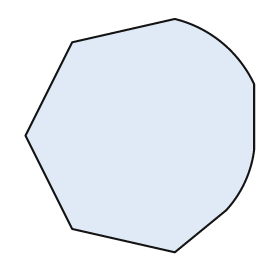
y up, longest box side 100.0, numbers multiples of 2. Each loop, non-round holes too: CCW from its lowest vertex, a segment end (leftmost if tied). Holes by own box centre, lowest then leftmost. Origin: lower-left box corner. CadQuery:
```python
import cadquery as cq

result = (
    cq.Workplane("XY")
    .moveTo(64.0, 0.0)
    .lineTo(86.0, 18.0)
    .threePointArc((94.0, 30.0), (98.0, 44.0))
    .lineTo(98.0, 72.0)
    .threePointArc((84.0, 90.0), (64.0, 100.0))
    .lineTo(20.0, 90.0)
    .lineTo(0.0, 50.0)
    .lineTo(20.0, 10.0)
    .close()
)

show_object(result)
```